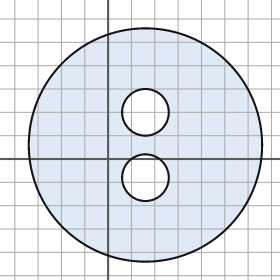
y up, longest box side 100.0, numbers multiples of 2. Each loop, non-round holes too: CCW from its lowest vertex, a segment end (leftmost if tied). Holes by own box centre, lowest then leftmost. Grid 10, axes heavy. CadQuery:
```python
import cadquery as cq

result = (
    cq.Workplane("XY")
    .moveTo(16.0, 6.0)
    .circle(50.0)
    .moveTo(16.0, -8.0)
    .circle(10.0)
    .moveTo(16.0, 20.0)
    .circle(10.0)
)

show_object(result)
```